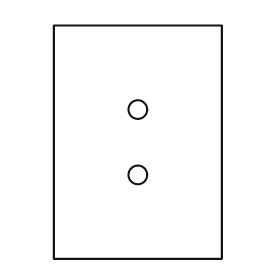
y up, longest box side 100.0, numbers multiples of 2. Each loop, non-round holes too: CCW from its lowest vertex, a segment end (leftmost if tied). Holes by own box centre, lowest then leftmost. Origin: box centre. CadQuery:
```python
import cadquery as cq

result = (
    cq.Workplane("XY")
    .moveTo(-36.0, -50.0)
    .lineTo(36.0, -50.0)
    .lineTo(36.0, 50.0)
    .lineTo(-36.0, 50.0)
    .close()
    .moveTo(0.0, -14.0)
    .circle(4.0)
    .moveTo(0.0, 14.0)
    .circle(4.0)
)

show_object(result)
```